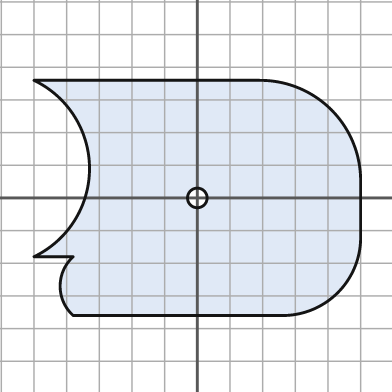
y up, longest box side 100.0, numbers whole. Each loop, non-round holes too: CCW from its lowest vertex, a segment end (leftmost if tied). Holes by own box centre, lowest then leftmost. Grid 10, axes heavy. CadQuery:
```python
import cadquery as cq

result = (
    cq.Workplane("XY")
    .moveTo(-38.0, -36.0)
    .lineTo(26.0, -36.0)
    .threePointArc((43.0, -29.0), (50.0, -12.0))
    .lineTo(50.0, 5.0)
    .threePointArc((41.0, 27.0), (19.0, 36.0))
    .lineTo(-50.0, 36.0)
    .threePointArc((-33.0, 9.0), (-50.0, -18.0))
    .lineTo(-38.0, -18.0)
    .threePointArc((-42.0, -27.0), (-38.0, -36.0))
    .close()
    .moveTo(0.0, 0.0)
    .circle(3.0)
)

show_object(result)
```